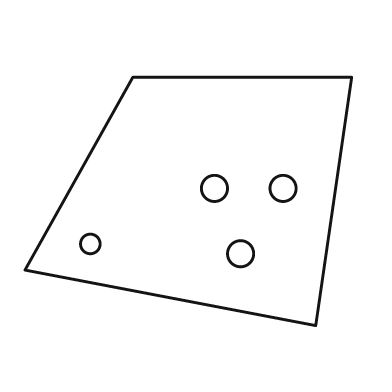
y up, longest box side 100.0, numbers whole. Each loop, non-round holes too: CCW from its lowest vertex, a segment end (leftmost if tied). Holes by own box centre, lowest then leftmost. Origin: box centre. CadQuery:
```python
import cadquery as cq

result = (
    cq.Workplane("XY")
    .moveTo(39.0, -38.0)
    .lineTo(50.0, 38.0)
    .lineTo(-17.0, 38.0)
    .lineTo(-50.0, -21.0)
    .close()
    .moveTo(16.0, -16.0)
    .circle(4.0)
    .moveTo(-30.0, -13.0)
    .circle(3.0)
    .moveTo(8.0, 4.0)
    .circle(4.0)
    .moveTo(29.0, 4.0)
    .circle(4.0)
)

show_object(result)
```